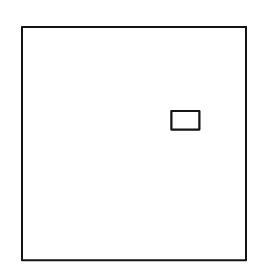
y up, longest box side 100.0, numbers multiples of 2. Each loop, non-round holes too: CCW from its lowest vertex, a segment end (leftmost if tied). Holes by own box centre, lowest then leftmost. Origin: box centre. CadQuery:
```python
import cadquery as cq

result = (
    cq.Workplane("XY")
    .moveTo(-48.0, -50.0)
    .lineTo(48.0, -50.0)
    .lineTo(48.0, 50.0)
    .lineTo(-48.0, 50.0)
    .close()
    .moveTo(16.0, 6.0)
    .lineTo(28.0, 6.0)
    .lineTo(28.0, 14.0)
    .lineTo(16.0, 14.0)
    .close()
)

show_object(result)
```